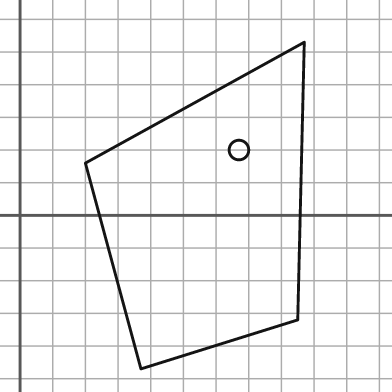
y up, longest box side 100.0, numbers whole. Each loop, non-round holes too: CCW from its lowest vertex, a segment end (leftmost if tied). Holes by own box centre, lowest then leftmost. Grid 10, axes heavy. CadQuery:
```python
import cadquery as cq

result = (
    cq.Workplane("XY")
    .moveTo(37.0, -47.0)
    .lineTo(85.0, -32.0)
    .lineTo(87.0, 53.0)
    .lineTo(20.0, 16.0)
    .close()
    .moveTo(67.0, 20.0)
    .circle(3.0)
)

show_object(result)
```